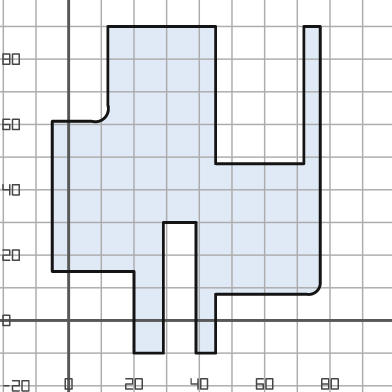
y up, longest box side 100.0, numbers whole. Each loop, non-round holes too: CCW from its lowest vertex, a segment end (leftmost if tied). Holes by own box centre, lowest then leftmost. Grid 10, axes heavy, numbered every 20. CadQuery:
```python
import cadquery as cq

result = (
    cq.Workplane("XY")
    .moveTo(20.0, -10.0)
    .lineTo(29.0, -10.0)
    .lineTo(29.0, 30.0)
    .lineTo(39.0, 30.0)
    .lineTo(39.0, -10.0)
    .lineTo(45.0, -10.0)
    .lineTo(45.0, 8.0)
    .lineTo(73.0, 8.0)
    .threePointArc((76.0, 9.0), (77.0, 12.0))
    .lineTo(77.0, 90.0)
    .lineTo(72.0, 90.0)
    .lineTo(72.0, 48.0)
    .lineTo(45.0, 48.0)
    .lineTo(45.0, 90.0)
    .lineTo(12.0, 90.0)
    .lineTo(12.0, 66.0)
    .threePointArc((11.0, 62.0), (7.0, 61.0))
    .lineTo(-5.0, 61.0)
    .lineTo(-5.0, 15.0)
    .lineTo(20.0, 15.0)
    .close()
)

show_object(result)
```